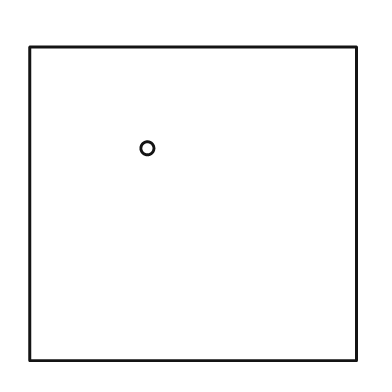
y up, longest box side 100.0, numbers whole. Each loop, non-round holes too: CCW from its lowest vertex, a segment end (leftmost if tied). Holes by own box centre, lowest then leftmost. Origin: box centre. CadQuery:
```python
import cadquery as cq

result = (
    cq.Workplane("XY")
    .moveTo(-50.0, -48.0)
    .lineTo(50.0, -48.0)
    .lineTo(50.0, 48.0)
    .lineTo(-50.0, 48.0)
    .close()
    .moveTo(-14.0, 17.0)
    .circle(2.0)
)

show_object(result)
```